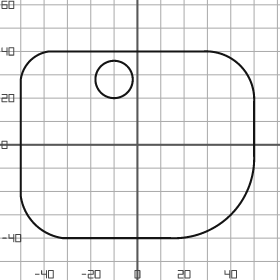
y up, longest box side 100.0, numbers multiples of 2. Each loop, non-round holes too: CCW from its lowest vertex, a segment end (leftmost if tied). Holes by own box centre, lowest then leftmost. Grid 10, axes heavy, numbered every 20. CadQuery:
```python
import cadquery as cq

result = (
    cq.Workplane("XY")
    .moveTo(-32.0, -40.0)
    .lineTo(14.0, -40.0)
    .threePointArc((40.0, -30.0), (50.0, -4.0))
    .lineTo(50.0, 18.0)
    .threePointArc((44.0, 34.0), (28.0, 40.0))
    .lineTo(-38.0, 40.0)
    .threePointArc((-46.0, 36.0), (-50.0, 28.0))
    .lineTo(-50.0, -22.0)
    .threePointArc((-44.0, -34.0), (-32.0, -40.0))
    .close()
    .moveTo(-10.0, 28.0)
    .circle(8.0)
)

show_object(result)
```